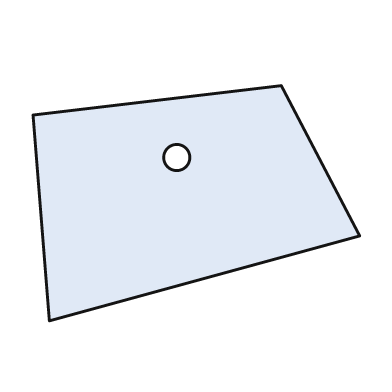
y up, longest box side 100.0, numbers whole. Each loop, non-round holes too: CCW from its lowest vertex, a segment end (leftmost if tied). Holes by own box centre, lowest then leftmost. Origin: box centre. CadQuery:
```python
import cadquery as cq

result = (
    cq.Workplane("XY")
    .moveTo(-45.0, -36.0)
    .lineTo(50.0, -10.0)
    .lineTo(26.0, 36.0)
    .lineTo(-50.0, 27.0)
    .close()
    .moveTo(-6.0, 14.0)
    .circle(4.0)
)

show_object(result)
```